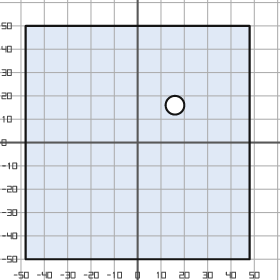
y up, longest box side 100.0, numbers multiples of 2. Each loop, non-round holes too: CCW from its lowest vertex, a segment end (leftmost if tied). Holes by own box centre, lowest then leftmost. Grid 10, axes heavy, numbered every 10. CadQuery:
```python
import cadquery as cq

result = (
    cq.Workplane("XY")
    .moveTo(-48.0, -50.0)
    .lineTo(48.0, -50.0)
    .lineTo(48.0, 50.0)
    .lineTo(-48.0, 50.0)
    .close()
    .moveTo(16.0, 16.0)
    .circle(4.0)
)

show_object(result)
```